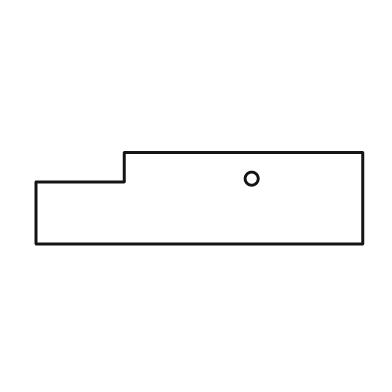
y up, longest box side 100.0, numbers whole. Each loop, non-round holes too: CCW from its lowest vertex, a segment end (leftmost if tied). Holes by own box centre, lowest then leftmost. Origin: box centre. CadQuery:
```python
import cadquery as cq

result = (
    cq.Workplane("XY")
    .moveTo(-50.0, -14.0)
    .lineTo(50.0, -14.0)
    .lineTo(50.0, 14.0)
    .lineTo(-23.0, 14.0)
    .lineTo(-23.0, 5.0)
    .lineTo(-50.0, 5.0)
    .close()
    .moveTo(16.0, 6.0)
    .circle(2.0)
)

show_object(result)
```